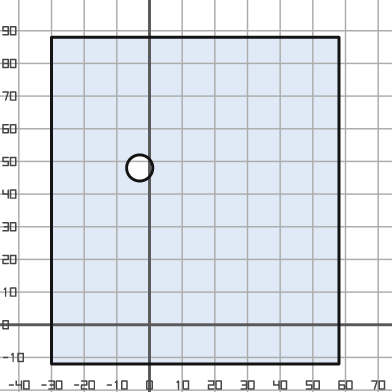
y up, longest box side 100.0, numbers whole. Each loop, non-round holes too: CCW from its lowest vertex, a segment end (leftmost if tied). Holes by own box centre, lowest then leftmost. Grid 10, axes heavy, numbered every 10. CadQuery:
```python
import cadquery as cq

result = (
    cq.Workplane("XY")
    .moveTo(-30.0, -12.0)
    .lineTo(58.0, -12.0)
    .lineTo(58.0, 88.0)
    .lineTo(-30.0, 88.0)
    .close()
    .moveTo(-3.0, 48.0)
    .circle(4.0)
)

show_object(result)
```